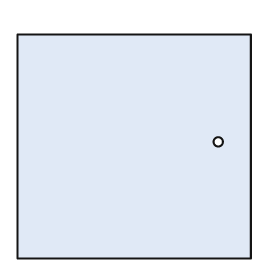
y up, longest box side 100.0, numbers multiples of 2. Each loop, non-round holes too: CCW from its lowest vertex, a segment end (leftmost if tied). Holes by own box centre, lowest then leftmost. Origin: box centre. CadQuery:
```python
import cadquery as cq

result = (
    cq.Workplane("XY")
    .moveTo(-50.0, -48.0)
    .lineTo(50.0, -48.0)
    .lineTo(50.0, 48.0)
    .lineTo(-50.0, 48.0)
    .close()
    .moveTo(36.0, 2.0)
    .circle(2.0)
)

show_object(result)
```